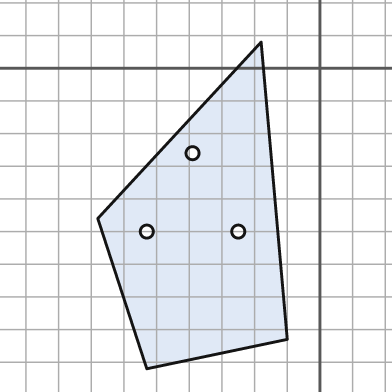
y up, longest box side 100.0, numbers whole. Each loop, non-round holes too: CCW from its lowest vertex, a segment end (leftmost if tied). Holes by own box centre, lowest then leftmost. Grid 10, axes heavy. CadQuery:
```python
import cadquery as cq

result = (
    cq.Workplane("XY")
    .moveTo(-53.0, -92.0)
    .lineTo(-10.0, -83.0)
    .lineTo(-18.0, 8.0)
    .lineTo(-68.0, -46.0)
    .close()
    .moveTo(-53.0, -50.0)
    .circle(2.0)
    .moveTo(-25.0, -50.0)
    .circle(2.0)
    .moveTo(-39.0, -26.0)
    .circle(2.0)
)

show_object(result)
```